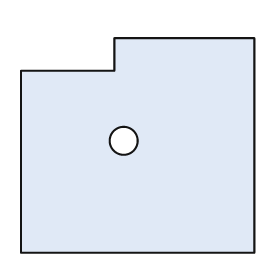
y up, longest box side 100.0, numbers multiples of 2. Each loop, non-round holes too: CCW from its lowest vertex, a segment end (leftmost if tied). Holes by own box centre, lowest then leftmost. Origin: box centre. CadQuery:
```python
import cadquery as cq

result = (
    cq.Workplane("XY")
    .moveTo(-50.0, -46.0)
    .lineTo(50.0, -46.0)
    .lineTo(50.0, 46.0)
    .lineTo(-10.0, 46.0)
    .lineTo(-10.0, 32.0)
    .lineTo(-50.0, 32.0)
    .close()
    .moveTo(-6.0, 2.0)
    .circle(6.0)
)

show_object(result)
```